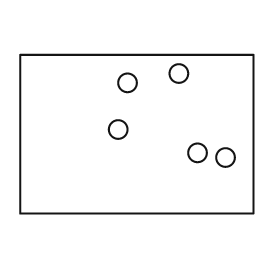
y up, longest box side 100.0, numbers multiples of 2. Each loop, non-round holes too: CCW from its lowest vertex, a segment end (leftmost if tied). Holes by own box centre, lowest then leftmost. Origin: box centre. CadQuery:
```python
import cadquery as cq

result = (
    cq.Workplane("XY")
    .moveTo(-50.0, -34.0)
    .lineTo(50.0, -34.0)
    .lineTo(50.0, 34.0)
    .lineTo(-50.0, 34.0)
    .close()
    .moveTo(38.0, -10.0)
    .circle(4.0)
    .moveTo(26.0, -8.0)
    .circle(4.0)
    .moveTo(-8.0, 2.0)
    .circle(4.0)
    .moveTo(-4.0, 22.0)
    .circle(4.0)
    .moveTo(18.0, 26.0)
    .circle(4.0)
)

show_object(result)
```